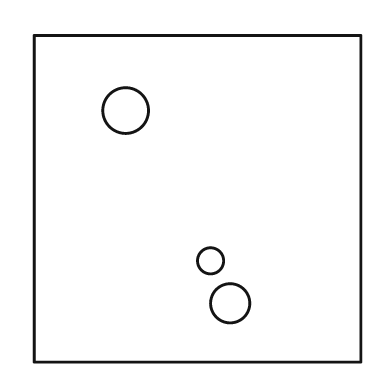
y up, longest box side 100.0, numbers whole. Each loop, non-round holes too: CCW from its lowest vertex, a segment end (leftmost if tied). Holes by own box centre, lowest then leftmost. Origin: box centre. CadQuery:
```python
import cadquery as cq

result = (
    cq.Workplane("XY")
    .moveTo(-50.0, -50.0)
    .lineTo(50.0, -50.0)
    .lineTo(50.0, 50.0)
    .lineTo(-50.0, 50.0)
    .close()
    .moveTo(10.0, -32.0)
    .circle(6.0)
    .moveTo(4.0, -19.0)
    .circle(4.0)
    .moveTo(-22.0, 27.0)
    .circle(7.0)
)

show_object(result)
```